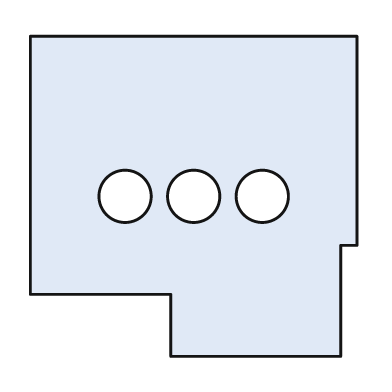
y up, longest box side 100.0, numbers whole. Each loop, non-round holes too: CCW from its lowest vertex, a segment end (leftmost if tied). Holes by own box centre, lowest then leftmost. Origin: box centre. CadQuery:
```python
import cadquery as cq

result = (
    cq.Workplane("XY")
    .moveTo(-7.0, -49.0)
    .lineTo(45.0, -49.0)
    .lineTo(45.0, -15.0)
    .lineTo(50.0, -15.0)
    .lineTo(50.0, 49.0)
    .lineTo(-50.0, 49.0)
    .lineTo(-50.0, -30.0)
    .lineTo(-7.0, -30.0)
    .close()
    .moveTo(-21.0, 0.0)
    .circle(8.0)
    .moveTo(0.0, 0.0)
    .circle(8.0)
    .moveTo(21.0, 0.0)
    .circle(8.0)
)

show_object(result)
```